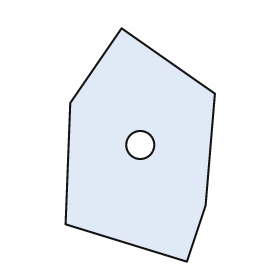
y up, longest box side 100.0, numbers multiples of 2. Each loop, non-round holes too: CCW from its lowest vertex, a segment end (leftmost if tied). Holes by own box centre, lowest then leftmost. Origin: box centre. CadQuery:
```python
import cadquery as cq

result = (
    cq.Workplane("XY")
    .moveTo(20.0, -50.0)
    .lineTo(28.0, -26.0)
    .lineTo(32.0, 22.0)
    .lineTo(-8.0, 50.0)
    .lineTo(-30.0, 18.0)
    .lineTo(-32.0, -34.0)
    .close()
    .moveTo(0.0, 0.0)
    .circle(6.0)
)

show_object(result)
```